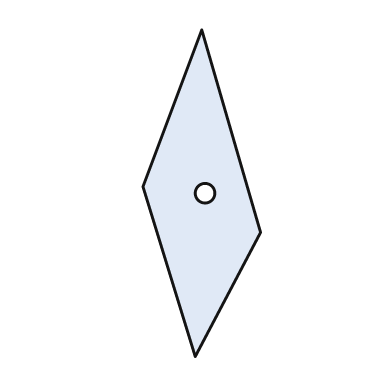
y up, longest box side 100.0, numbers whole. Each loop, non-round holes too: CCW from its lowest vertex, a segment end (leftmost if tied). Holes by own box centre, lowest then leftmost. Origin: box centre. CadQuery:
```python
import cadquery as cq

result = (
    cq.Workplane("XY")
    .moveTo(-2.0, -50.0)
    .lineTo(18.0, -12.0)
    .lineTo(0.0, 50.0)
    .lineTo(-18.0, 2.0)
    .close()
    .moveTo(1.0, 0.0)
    .circle(3.0)
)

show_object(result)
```